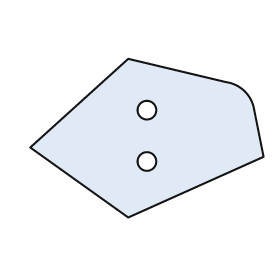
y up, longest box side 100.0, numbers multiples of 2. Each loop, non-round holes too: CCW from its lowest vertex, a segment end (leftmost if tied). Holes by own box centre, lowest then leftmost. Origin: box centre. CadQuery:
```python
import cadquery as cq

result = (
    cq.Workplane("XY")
    .moveTo(-8.0, -34.0)
    .lineTo(50.0, -8.0)
    .lineTo(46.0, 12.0)
    .threePointArc((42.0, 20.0), (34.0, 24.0))
    .lineTo(-8.0, 34.0)
    .lineTo(-50.0, -4.0)
    .close()
    .moveTo(0.0, -10.0)
    .circle(4.0)
    .moveTo(0.0, 12.0)
    .circle(4.0)
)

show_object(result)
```